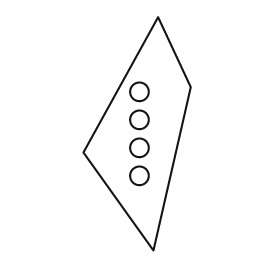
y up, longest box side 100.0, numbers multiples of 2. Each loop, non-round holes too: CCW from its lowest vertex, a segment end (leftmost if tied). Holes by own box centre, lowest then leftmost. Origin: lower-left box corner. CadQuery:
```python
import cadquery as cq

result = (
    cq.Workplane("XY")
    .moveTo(30.0, 0.0)
    .lineTo(46.0, 70.0)
    .lineTo(32.0, 100.0)
    .lineTo(0.0, 42.0)
    .close()
    .moveTo(24.0, 32.0)
    .circle(4.0)
    .moveTo(24.0, 44.0)
    .circle(4.0)
    .moveTo(24.0, 56.0)
    .circle(4.0)
    .moveTo(24.0, 68.0)
    .circle(4.0)
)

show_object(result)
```